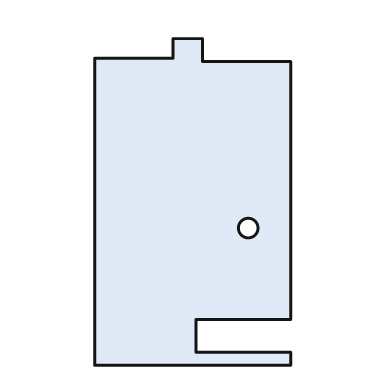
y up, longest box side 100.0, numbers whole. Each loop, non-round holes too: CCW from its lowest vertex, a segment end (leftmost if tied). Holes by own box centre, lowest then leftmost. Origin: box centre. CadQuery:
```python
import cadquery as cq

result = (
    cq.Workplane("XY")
    .moveTo(-30.0, -50.0)
    .lineTo(30.0, -50.0)
    .lineTo(30.0, -46.0)
    .lineTo(1.0, -46.0)
    .lineTo(1.0, -36.0)
    .lineTo(30.0, -36.0)
    .lineTo(30.0, 43.0)
    .lineTo(3.0, 43.0)
    .lineTo(3.0, 50.0)
    .lineTo(-6.0, 50.0)
    .lineTo(-6.0, 44.0)
    .lineTo(-30.0, 44.0)
    .close()
    .moveTo(17.0, -8.0)
    .circle(3.0)
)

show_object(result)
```